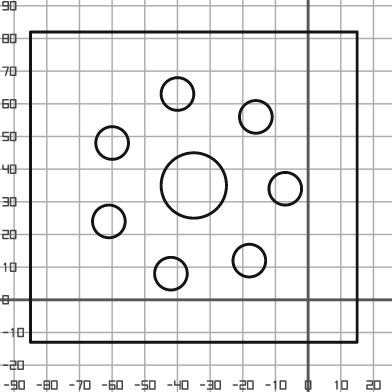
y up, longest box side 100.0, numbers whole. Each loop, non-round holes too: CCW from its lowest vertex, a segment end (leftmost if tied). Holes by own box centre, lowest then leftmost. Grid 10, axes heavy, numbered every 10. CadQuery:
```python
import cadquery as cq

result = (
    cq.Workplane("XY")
    .moveTo(-85.0, -13.0)
    .lineTo(15.0, -13.0)
    .lineTo(15.0, 82.0)
    .lineTo(-85.0, 82.0)
    .close()
    .moveTo(-42.0, 8.0)
    .circle(5.0)
    .moveTo(-18.0, 12.0)
    .circle(5.0)
    .moveTo(-61.0, 24.0)
    .circle(5.0)
    .moveTo(-7.0, 34.0)
    .circle(5.0)
    .moveTo(-35.0, 35.0)
    .circle(10.0)
    .moveTo(-60.0, 48.0)
    .circle(5.0)
    .moveTo(-16.0, 56.0)
    .circle(5.0)
    .moveTo(-40.0, 63.0)
    .circle(5.0)
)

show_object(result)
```